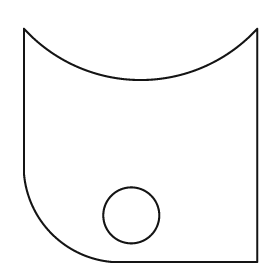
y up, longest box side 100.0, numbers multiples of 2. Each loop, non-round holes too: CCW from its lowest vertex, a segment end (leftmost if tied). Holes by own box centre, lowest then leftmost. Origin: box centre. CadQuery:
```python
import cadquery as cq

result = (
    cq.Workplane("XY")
    .moveTo(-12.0, -50.0)
    .lineTo(50.0, -50.0)
    .lineTo(50.0, 50.0)
    .threePointArc((0.0, 28.0), (-50.0, 50.0))
    .lineTo(-50.0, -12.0)
    .threePointArc((-38.0, -38.0), (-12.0, -50.0))
    .close()
    .moveTo(-4.0, -30.0)
    .circle(12.0)
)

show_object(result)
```